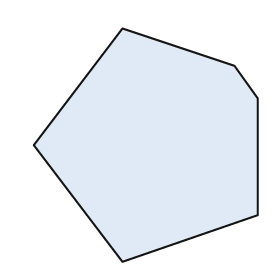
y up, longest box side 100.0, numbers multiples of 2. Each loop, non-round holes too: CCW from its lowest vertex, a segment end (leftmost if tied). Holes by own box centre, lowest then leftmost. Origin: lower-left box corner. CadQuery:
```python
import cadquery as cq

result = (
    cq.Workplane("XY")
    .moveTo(38.0, 0.0)
    .lineTo(96.0, 20.0)
    .lineTo(96.0, 70.0)
    .lineTo(86.0, 84.0)
    .lineTo(38.0, 100.0)
    .lineTo(0.0, 50.0)
    .close()
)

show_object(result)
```